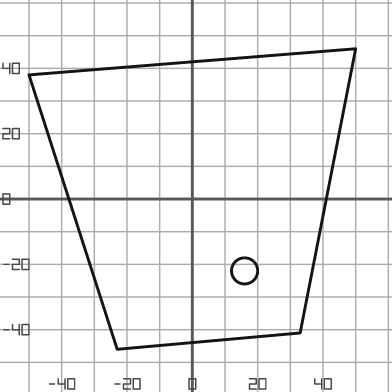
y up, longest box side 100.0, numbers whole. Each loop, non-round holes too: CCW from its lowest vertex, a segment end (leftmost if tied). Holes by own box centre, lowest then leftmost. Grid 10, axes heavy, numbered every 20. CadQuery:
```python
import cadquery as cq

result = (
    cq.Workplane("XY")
    .moveTo(-23.0, -46.0)
    .lineTo(33.0, -41.0)
    .lineTo(50.0, 46.0)
    .lineTo(-50.0, 38.0)
    .close()
    .moveTo(16.0, -22.0)
    .circle(4.0)
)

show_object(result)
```